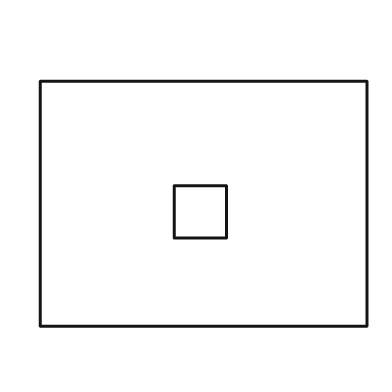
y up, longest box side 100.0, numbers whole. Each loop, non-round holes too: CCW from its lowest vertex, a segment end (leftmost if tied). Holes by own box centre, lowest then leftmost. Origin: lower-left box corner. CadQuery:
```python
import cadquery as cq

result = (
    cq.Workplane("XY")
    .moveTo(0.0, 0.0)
    .lineTo(100.0, 0.0)
    .lineTo(100.0, 75.0)
    .lineTo(0.0, 75.0)
    .close()
    .moveTo(41.0, 27.0)
    .lineTo(57.0, 27.0)
    .lineTo(57.0, 43.0)
    .lineTo(41.0, 43.0)
    .close()
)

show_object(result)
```